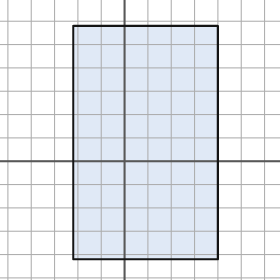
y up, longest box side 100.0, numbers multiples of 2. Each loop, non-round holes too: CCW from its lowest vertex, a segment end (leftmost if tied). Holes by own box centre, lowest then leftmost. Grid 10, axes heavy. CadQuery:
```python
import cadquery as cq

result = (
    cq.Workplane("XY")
    .moveTo(-22.0, -42.0)
    .lineTo(40.0, -42.0)
    .lineTo(40.0, 58.0)
    .lineTo(-22.0, 58.0)
    .close()
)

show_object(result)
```